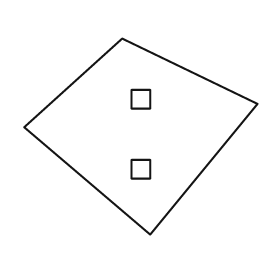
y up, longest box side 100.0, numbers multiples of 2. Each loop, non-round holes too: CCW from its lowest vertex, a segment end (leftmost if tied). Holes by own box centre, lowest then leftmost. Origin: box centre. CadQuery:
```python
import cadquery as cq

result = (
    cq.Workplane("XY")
    .moveTo(4.0, -42.0)
    .lineTo(50.0, 14.0)
    .lineTo(-8.0, 42.0)
    .lineTo(-50.0, 4.0)
    .close()
    .moveTo(-4.0, -18.0)
    .lineTo(4.0, -18.0)
    .lineTo(4.0, -10.0)
    .lineTo(-4.0, -10.0)
    .close()
    .moveTo(-4.0, 12.0)
    .lineTo(4.0, 12.0)
    .lineTo(4.0, 20.0)
    .lineTo(-4.0, 20.0)
    .close()
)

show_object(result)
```